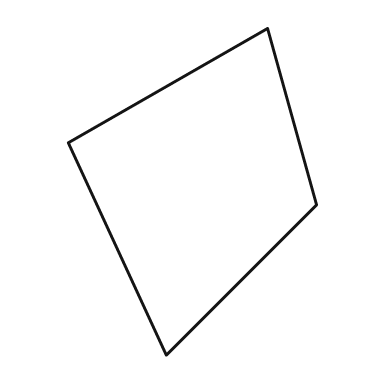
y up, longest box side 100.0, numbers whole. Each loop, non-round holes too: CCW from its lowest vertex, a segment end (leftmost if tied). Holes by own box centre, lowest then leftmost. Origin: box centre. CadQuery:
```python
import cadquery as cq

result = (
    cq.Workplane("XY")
    .moveTo(-8.0, -50.0)
    .lineTo(38.0, -4.0)
    .lineTo(23.0, 50.0)
    .lineTo(-38.0, 15.0)
    .close()
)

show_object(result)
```